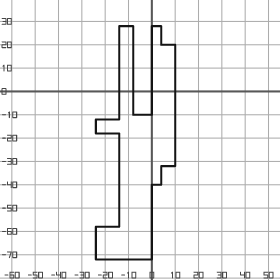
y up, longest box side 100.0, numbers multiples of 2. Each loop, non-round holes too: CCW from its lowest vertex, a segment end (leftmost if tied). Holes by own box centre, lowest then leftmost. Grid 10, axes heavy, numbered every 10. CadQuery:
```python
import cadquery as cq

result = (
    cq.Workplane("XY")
    .moveTo(-24.0, -72.0)
    .lineTo(0.0, -72.0)
    .lineTo(0.0, -40.0)
    .lineTo(4.0, -40.0)
    .lineTo(4.0, -32.0)
    .lineTo(10.0, -32.0)
    .lineTo(10.0, 20.0)
    .lineTo(4.0, 20.0)
    .lineTo(4.0, 28.0)
    .lineTo(0.0, 28.0)
    .lineTo(0.0, -10.0)
    .lineTo(-8.0, -10.0)
    .lineTo(-8.0, 28.0)
    .lineTo(-14.0, 28.0)
    .lineTo(-14.0, -12.0)
    .lineTo(-24.0, -12.0)
    .lineTo(-24.0, -18.0)
    .lineTo(-14.0, -18.0)
    .lineTo(-14.0, -58.0)
    .lineTo(-24.0, -58.0)
    .close()
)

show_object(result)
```